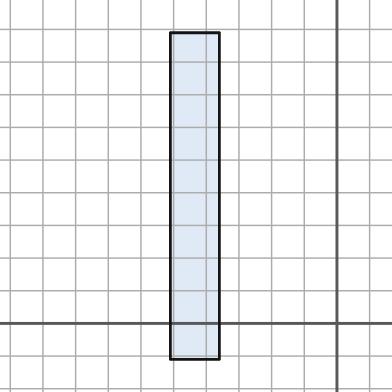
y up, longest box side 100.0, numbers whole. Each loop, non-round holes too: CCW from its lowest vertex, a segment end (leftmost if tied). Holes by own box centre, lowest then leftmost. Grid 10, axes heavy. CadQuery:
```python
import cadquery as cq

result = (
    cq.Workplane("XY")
    .moveTo(-51.0, -11.0)
    .lineTo(-36.0, -11.0)
    .lineTo(-36.0, 89.0)
    .lineTo(-51.0, 89.0)
    .close()
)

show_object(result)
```